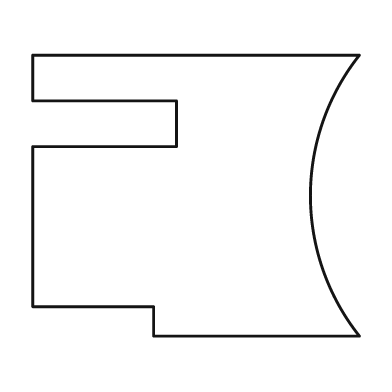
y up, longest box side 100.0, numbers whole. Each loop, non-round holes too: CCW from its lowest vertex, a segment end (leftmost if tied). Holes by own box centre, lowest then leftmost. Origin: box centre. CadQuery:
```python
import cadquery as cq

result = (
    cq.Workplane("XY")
    .moveTo(-13.0, -43.0)
    .lineTo(50.0, -43.0)
    .threePointArc((35.0, 0.0), (50.0, 43.0))
    .lineTo(-50.0, 43.0)
    .lineTo(-50.0, 29.0)
    .lineTo(-6.0, 29.0)
    .lineTo(-6.0, 15.0)
    .lineTo(-50.0, 15.0)
    .lineTo(-50.0, -34.0)
    .lineTo(-13.0, -34.0)
    .close()
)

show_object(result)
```